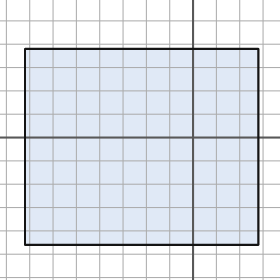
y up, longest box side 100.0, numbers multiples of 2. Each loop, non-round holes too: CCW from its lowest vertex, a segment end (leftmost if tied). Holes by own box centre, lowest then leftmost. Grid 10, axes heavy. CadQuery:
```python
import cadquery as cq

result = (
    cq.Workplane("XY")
    .moveTo(-72.0, -46.0)
    .lineTo(28.0, -46.0)
    .lineTo(28.0, 38.0)
    .lineTo(-72.0, 38.0)
    .close()
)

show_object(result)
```